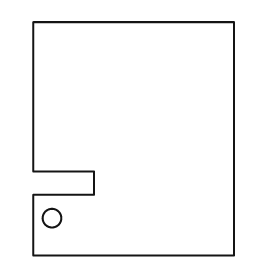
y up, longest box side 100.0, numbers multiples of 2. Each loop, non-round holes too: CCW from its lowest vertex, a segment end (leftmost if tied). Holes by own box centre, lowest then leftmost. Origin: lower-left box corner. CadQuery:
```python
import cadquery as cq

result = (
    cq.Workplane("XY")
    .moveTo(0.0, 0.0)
    .lineTo(86.0, 0.0)
    .lineTo(86.0, 100.0)
    .lineTo(0.0, 100.0)
    .lineTo(0.0, 36.0)
    .lineTo(26.0, 36.0)
    .lineTo(26.0, 26.0)
    .lineTo(0.0, 26.0)
    .close()
    .moveTo(8.0, 16.0)
    .circle(4.0)
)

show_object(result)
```